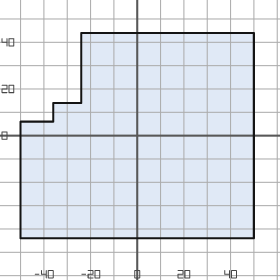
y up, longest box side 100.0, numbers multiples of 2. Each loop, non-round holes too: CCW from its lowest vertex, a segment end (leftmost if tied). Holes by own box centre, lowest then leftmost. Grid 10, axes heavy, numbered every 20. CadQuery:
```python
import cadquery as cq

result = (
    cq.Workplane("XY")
    .moveTo(-50.0, -44.0)
    .lineTo(50.0, -44.0)
    .lineTo(50.0, 44.0)
    .lineTo(-24.0, 44.0)
    .lineTo(-24.0, 14.0)
    .lineTo(-36.0, 14.0)
    .lineTo(-36.0, 6.0)
    .lineTo(-50.0, 6.0)
    .close()
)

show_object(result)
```